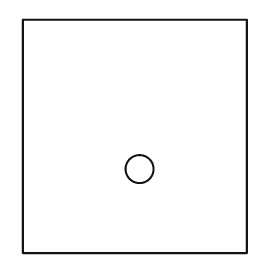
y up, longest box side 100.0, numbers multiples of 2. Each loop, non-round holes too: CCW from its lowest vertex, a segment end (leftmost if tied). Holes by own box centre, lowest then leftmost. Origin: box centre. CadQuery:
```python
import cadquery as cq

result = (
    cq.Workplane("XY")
    .moveTo(-48.0, -50.0)
    .lineTo(48.0, -50.0)
    .lineTo(48.0, 50.0)
    .lineTo(-48.0, 50.0)
    .close()
    .moveTo(2.0, -14.0)
    .circle(6.0)
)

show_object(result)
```